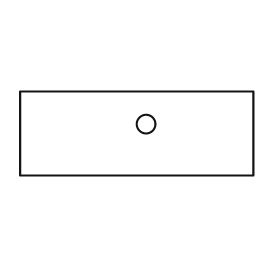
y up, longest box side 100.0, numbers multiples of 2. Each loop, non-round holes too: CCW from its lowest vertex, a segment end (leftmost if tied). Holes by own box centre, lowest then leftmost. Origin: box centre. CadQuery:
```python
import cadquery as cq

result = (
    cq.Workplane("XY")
    .moveTo(-50.0, -18.0)
    .lineTo(50.0, -18.0)
    .lineTo(50.0, 18.0)
    .lineTo(-50.0, 18.0)
    .close()
    .moveTo(4.0, 4.0)
    .circle(4.0)
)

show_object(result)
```